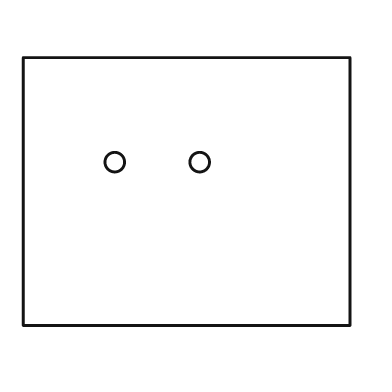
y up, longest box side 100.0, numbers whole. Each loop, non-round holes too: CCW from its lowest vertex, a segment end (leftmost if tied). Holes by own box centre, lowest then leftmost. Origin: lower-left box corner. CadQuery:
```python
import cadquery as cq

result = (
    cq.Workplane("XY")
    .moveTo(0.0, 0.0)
    .lineTo(100.0, 0.0)
    .lineTo(100.0, 82.0)
    .lineTo(0.0, 82.0)
    .close()
    .moveTo(28.0, 50.0)
    .circle(3.0)
    .moveTo(54.0, 50.0)
    .circle(3.0)
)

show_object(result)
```